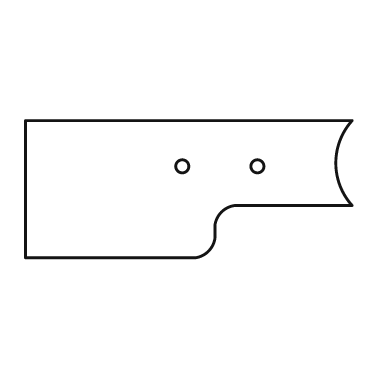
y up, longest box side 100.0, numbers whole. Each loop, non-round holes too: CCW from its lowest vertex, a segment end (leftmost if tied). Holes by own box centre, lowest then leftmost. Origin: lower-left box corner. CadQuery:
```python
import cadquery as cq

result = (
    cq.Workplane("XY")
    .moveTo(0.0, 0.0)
    .lineTo(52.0, 0.0)
    .threePointArc((56.0, 2.0), (58.0, 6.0))
    .lineTo(58.0, 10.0)
    .threePointArc((60.0, 14.0), (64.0, 16.0))
    .lineTo(100.0, 16.0)
    .threePointArc((95.0, 29.0), (100.0, 42.0))
    .lineTo(0.0, 42.0)
    .close()
    .moveTo(48.0, 28.0)
    .circle(2.0)
    .moveTo(71.0, 28.0)
    .circle(2.0)
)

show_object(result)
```